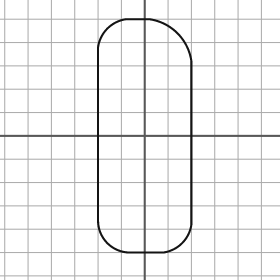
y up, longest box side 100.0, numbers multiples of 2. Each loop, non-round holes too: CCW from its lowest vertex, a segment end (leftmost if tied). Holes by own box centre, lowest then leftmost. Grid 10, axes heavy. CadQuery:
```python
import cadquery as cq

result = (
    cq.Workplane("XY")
    .moveTo(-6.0, -50.0)
    .lineTo(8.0, -50.0)
    .threePointArc((16.0, -46.0), (20.0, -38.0))
    .lineTo(20.0, 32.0)
    .threePointArc((14.0, 44.0), (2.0, 50.0))
    .lineTo(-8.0, 50.0)
    .threePointArc((-16.0, 46.0), (-20.0, 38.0))
    .lineTo(-20.0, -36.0)
    .threePointArc((-16.0, -46.0), (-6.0, -50.0))
    .close()
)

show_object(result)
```